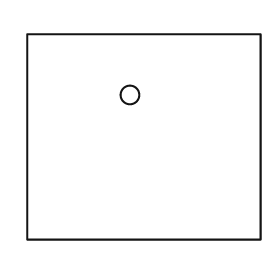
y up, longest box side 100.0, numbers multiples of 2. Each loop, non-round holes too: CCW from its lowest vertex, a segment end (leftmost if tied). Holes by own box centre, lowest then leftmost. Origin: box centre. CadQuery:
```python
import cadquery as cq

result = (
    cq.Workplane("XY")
    .moveTo(-50.0, -44.0)
    .lineTo(50.0, -44.0)
    .lineTo(50.0, 44.0)
    .lineTo(-50.0, 44.0)
    .close()
    .moveTo(-6.0, 18.0)
    .circle(4.0)
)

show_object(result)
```